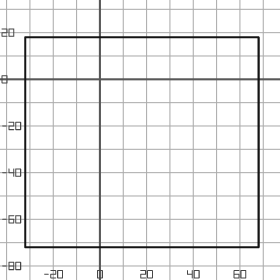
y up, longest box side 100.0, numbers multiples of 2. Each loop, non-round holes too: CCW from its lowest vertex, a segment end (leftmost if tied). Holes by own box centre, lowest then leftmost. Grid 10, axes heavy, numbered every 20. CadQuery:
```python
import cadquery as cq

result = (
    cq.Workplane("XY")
    .moveTo(-32.0, -72.0)
    .lineTo(68.0, -72.0)
    .lineTo(68.0, 18.0)
    .lineTo(-32.0, 18.0)
    .close()
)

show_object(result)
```